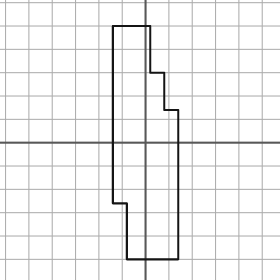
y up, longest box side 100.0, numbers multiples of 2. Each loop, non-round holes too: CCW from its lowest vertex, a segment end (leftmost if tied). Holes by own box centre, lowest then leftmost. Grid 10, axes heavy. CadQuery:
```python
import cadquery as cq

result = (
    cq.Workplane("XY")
    .moveTo(-8.0, -50.0)
    .lineTo(14.0, -50.0)
    .lineTo(14.0, 14.0)
    .lineTo(8.0, 14.0)
    .lineTo(8.0, 30.0)
    .lineTo(2.0, 30.0)
    .lineTo(2.0, 50.0)
    .lineTo(-14.0, 50.0)
    .lineTo(-14.0, -26.0)
    .lineTo(-8.0, -26.0)
    .close()
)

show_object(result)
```